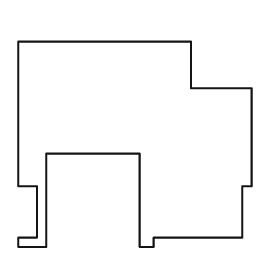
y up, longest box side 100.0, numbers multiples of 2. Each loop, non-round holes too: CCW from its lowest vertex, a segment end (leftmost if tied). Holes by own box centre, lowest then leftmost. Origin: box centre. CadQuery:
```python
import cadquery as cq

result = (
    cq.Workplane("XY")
    .moveTo(-50.0, -44.0)
    .lineTo(-38.0, -44.0)
    .lineTo(-38.0, -4.0)
    .lineTo(2.0, -4.0)
    .lineTo(2.0, -44.0)
    .lineTo(8.0, -44.0)
    .lineTo(8.0, -40.0)
    .lineTo(46.0, -40.0)
    .lineTo(46.0, -18.0)
    .lineTo(50.0, -18.0)
    .lineTo(50.0, 24.0)
    .lineTo(24.0, 24.0)
    .lineTo(24.0, 44.0)
    .lineTo(-50.0, 44.0)
    .lineTo(-50.0, -18.0)
    .lineTo(-42.0, -18.0)
    .lineTo(-42.0, -40.0)
    .lineTo(-50.0, -40.0)
    .close()
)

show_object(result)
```